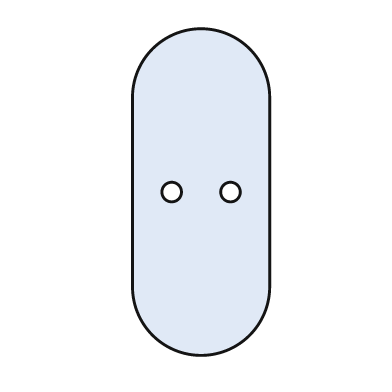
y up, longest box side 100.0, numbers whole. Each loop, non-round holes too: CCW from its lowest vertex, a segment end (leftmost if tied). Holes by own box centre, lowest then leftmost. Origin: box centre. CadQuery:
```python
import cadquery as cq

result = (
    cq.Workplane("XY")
    .moveTo(-21.0, -29.0)
    .threePointArc((0.0, -50.0), (21.0, -29.0))
    .lineTo(21.0, 29.0)
    .threePointArc((0.0, 50.0), (-21.0, 29.0))
    .close()
    .moveTo(-9.0, 0.0)
    .circle(3.0)
    .moveTo(9.0, 0.0)
    .circle(3.0)
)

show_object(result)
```